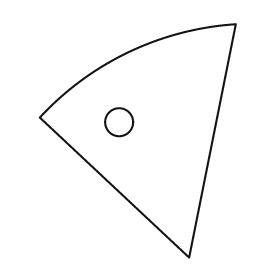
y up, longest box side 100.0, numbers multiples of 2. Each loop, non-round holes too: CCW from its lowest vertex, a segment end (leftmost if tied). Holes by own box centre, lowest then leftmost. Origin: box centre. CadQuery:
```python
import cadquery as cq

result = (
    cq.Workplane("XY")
    .moveTo(22.0, -50.0)
    .lineTo(42.0, 50.0)
    .threePointArc((-4.0, 38.0), (-42.0, 10.0))
    .close()
    .moveTo(-8.0, 8.0)
    .circle(6.0)
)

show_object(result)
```